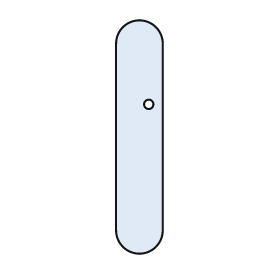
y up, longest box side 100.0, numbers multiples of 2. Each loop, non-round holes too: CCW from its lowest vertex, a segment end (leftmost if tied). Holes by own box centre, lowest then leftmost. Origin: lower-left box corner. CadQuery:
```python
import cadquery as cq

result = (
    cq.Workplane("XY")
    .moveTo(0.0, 10.0)
    .threePointArc((10.0, 0.0), (20.0, 10.0))
    .lineTo(20.0, 90.0)
    .threePointArc((10.0, 100.0), (0.0, 90.0))
    .close()
    .moveTo(14.0, 64.0)
    .circle(2.0)
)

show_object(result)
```